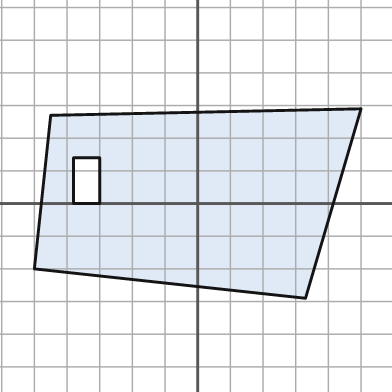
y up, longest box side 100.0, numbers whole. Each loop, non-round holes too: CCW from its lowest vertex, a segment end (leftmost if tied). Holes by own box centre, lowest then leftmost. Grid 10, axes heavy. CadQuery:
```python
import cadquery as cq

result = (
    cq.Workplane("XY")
    .moveTo(33.0, -29.0)
    .lineTo(50.0, 29.0)
    .lineTo(-45.0, 27.0)
    .lineTo(-50.0, -20.0)
    .close()
    .moveTo(-38.0, 0.0)
    .lineTo(-30.0, 0.0)
    .lineTo(-30.0, 14.0)
    .lineTo(-38.0, 14.0)
    .close()
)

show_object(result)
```